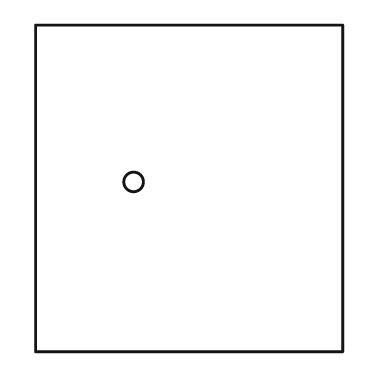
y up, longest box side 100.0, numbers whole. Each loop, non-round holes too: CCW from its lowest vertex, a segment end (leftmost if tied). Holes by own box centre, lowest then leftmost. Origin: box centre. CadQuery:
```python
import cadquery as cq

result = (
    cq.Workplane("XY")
    .moveTo(-47.0, -50.0)
    .lineTo(47.0, -50.0)
    .lineTo(47.0, 50.0)
    .lineTo(-47.0, 50.0)
    .close()
    .moveTo(-17.0, 2.0)
    .circle(3.0)
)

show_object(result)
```